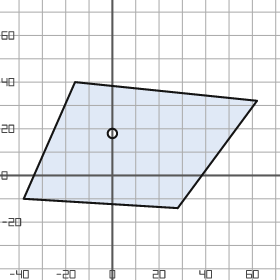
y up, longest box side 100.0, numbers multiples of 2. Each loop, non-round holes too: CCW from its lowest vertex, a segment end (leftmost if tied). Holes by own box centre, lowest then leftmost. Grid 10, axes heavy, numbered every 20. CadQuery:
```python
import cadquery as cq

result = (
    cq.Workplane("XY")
    .moveTo(28.0, -14.0)
    .lineTo(62.0, 32.0)
    .lineTo(-16.0, 40.0)
    .lineTo(-38.0, -10.0)
    .close()
    .moveTo(0.0, 18.0)
    .circle(2.0)
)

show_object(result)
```